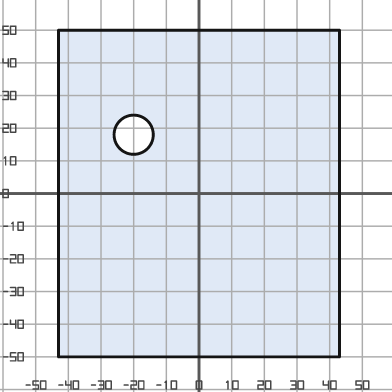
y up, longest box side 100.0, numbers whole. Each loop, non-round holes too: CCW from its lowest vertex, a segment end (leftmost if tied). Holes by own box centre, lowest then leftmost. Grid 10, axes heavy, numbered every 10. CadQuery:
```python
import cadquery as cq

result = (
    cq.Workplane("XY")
    .moveTo(-43.0, -50.0)
    .lineTo(43.0, -50.0)
    .lineTo(43.0, 50.0)
    .lineTo(-43.0, 50.0)
    .close()
    .moveTo(-20.0, 18.0)
    .circle(6.0)
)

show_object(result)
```